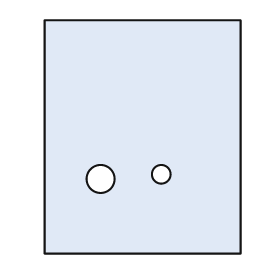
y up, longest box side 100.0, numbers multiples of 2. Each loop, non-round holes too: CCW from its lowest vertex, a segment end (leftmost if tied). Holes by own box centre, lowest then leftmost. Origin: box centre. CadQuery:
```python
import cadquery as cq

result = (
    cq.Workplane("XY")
    .moveTo(-42.0, -50.0)
    .lineTo(42.0, -50.0)
    .lineTo(42.0, 50.0)
    .lineTo(-42.0, 50.0)
    .close()
    .moveTo(-18.0, -18.0)
    .circle(6.0)
    .moveTo(8.0, -16.0)
    .circle(4.0)
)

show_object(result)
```